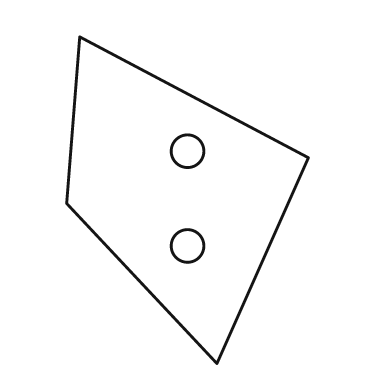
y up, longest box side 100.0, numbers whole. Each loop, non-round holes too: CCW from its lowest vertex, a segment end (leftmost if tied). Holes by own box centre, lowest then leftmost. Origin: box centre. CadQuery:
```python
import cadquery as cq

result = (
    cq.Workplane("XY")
    .moveTo(9.0, -50.0)
    .lineTo(37.0, 13.0)
    .lineTo(-33.0, 50.0)
    .lineTo(-37.0, -1.0)
    .close()
    .moveTo(0.0, -14.0)
    .circle(5.0)
    .moveTo(0.0, 15.0)
    .circle(5.0)
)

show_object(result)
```